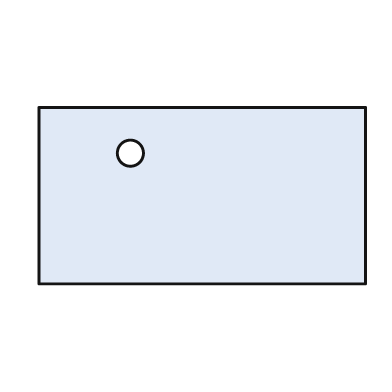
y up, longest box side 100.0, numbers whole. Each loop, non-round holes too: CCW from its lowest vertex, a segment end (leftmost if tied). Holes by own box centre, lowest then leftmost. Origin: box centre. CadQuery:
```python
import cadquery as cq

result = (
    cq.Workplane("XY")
    .moveTo(-50.0, -27.0)
    .lineTo(50.0, -27.0)
    .lineTo(50.0, 27.0)
    .lineTo(-50.0, 27.0)
    .close()
    .moveTo(-22.0, 13.0)
    .circle(4.0)
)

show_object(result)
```